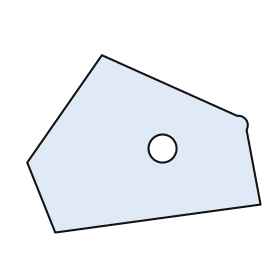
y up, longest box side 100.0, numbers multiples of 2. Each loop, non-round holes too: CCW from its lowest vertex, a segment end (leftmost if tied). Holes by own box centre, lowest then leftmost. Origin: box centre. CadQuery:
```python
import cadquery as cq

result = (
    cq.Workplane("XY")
    .moveTo(-38.0, -38.0)
    .lineTo(50.0, -26.0)
    .lineTo(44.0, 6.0)
    .threePointArc((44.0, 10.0), (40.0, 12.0))
    .lineTo(-18.0, 38.0)
    .lineTo(-50.0, -8.0)
    .close()
    .moveTo(8.0, -2.0)
    .circle(6.0)
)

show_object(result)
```